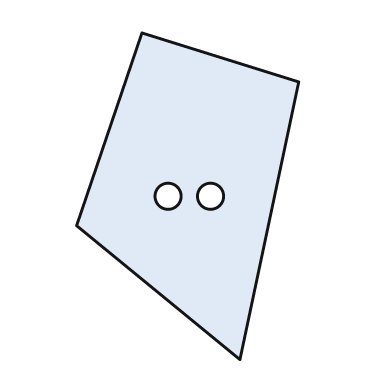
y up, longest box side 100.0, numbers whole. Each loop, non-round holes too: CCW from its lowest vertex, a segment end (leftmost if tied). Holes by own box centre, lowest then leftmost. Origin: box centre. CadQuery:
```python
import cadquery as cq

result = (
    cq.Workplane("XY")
    .moveTo(16.0, -50.0)
    .lineTo(34.0, 35.0)
    .lineTo(-14.0, 50.0)
    .lineTo(-34.0, -9.0)
    .close()
    .moveTo(-6.0, 0.0)
    .circle(4.0)
    .moveTo(7.0, 0.0)
    .circle(4.0)
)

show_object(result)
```